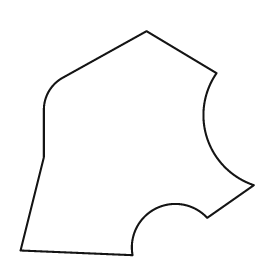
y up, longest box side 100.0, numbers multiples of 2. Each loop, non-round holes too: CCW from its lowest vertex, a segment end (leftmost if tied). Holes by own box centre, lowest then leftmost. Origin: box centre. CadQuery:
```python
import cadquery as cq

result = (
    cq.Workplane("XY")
    .moveTo(-2.0, -48.0)
    .threePointArc((8.0, -28.0), (30.0, -32.0))
    .lineTo(50.0, -18.0)
    .threePointArc((30.0, 2.0), (34.0, 30.0))
    .lineTo(4.0, 48.0)
    .lineTo(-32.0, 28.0)
    .threePointArc((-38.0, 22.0), (-40.0, 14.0))
    .lineTo(-40.0, -6.0)
    .lineTo(-50.0, -46.0)
    .close()
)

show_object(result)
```